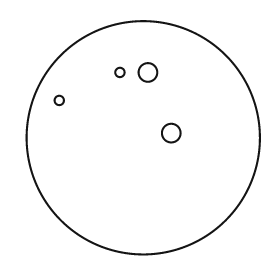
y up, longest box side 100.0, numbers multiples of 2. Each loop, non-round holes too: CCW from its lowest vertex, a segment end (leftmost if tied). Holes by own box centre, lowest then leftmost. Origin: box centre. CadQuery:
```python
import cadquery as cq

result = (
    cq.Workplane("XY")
    .moveTo(0.0, 0.0)
    .circle(50.0)
    .moveTo(12.0, 2.0)
    .circle(4.0)
    .moveTo(-36.0, 16.0)
    .circle(2.0)
    .moveTo(-10.0, 28.0)
    .circle(2.0)
    .moveTo(2.0, 28.0)
    .circle(4.0)
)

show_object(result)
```